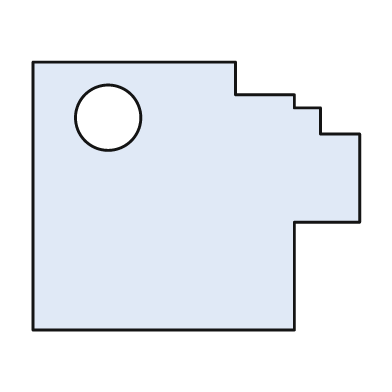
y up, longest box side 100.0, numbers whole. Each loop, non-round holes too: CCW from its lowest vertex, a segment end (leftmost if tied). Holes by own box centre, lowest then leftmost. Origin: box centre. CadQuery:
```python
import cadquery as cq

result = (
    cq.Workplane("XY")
    .moveTo(-50.0, -41.0)
    .lineTo(30.0, -41.0)
    .lineTo(30.0, -8.0)
    .lineTo(50.0, -8.0)
    .lineTo(50.0, 19.0)
    .lineTo(38.0, 19.0)
    .lineTo(38.0, 27.0)
    .lineTo(30.0, 27.0)
    .lineTo(30.0, 31.0)
    .lineTo(12.0, 31.0)
    .lineTo(12.0, 41.0)
    .lineTo(-50.0, 41.0)
    .close()
    .moveTo(-27.0, 24.0)
    .circle(10.0)
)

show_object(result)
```